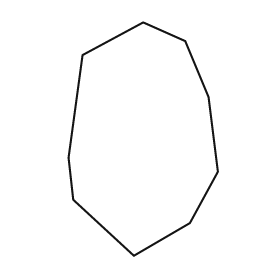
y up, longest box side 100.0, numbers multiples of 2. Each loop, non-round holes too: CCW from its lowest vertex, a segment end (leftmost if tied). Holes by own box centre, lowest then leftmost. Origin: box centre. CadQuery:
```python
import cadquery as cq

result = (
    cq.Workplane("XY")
    .moveTo(-4.0, -50.0)
    .lineTo(20.0, -36.0)
    .lineTo(32.0, -14.0)
    .lineTo(28.0, 18.0)
    .lineTo(18.0, 42.0)
    .lineTo(0.0, 50.0)
    .lineTo(-26.0, 36.0)
    .lineTo(-32.0, -8.0)
    .lineTo(-30.0, -26.0)
    .close()
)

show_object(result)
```